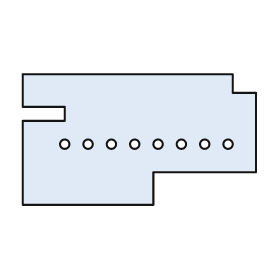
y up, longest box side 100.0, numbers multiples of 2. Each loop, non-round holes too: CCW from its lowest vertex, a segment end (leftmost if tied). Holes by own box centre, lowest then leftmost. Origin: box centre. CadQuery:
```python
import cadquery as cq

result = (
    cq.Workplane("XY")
    .moveTo(-50.0, -28.0)
    .lineTo(6.0, -28.0)
    .lineTo(6.0, -14.0)
    .lineTo(50.0, -14.0)
    .lineTo(50.0, 20.0)
    .lineTo(40.0, 20.0)
    .lineTo(40.0, 28.0)
    .lineTo(-50.0, 28.0)
    .lineTo(-50.0, 14.0)
    .lineTo(-32.0, 14.0)
    .lineTo(-32.0, 8.0)
    .lineTo(-50.0, 8.0)
    .close()
    .moveTo(-32.0, -2.0)
    .circle(2.0)
    .moveTo(-22.0, -2.0)
    .circle(2.0)
    .moveTo(-12.0, -2.0)
    .circle(2.0)
    .moveTo(-2.0, -2.0)
    .circle(2.0)
    .moveTo(8.0, -2.0)
    .circle(2.0)
    .moveTo(18.0, -2.0)
    .circle(2.0)
    .moveTo(28.0, -2.0)
    .circle(2.0)
    .moveTo(38.0, -2.0)
    .circle(2.0)
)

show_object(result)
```